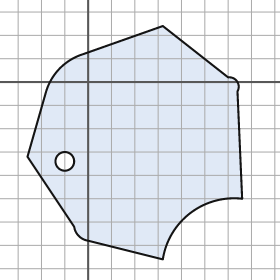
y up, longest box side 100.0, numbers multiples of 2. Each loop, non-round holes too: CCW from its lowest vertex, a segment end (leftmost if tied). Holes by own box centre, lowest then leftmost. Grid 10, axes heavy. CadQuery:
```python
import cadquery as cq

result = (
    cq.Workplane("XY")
    .moveTo(32.0, -76.0)
    .threePointArc((44.0, -56.0), (66.0, -50.0))
    .lineTo(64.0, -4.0)
    .threePointArc((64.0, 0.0), (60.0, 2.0))
    .lineTo(32.0, 24.0)
    .lineTo(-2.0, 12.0)
    .threePointArc((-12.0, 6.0), (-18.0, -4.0))
    .lineTo(-26.0, -32.0)
    .lineTo(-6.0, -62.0)
    .threePointArc((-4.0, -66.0), (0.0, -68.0))
    .close()
    .moveTo(-10.0, -34.0)
    .circle(4.0)
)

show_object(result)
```